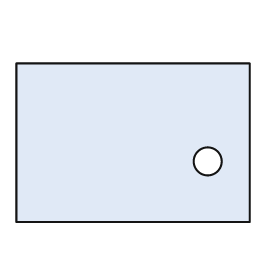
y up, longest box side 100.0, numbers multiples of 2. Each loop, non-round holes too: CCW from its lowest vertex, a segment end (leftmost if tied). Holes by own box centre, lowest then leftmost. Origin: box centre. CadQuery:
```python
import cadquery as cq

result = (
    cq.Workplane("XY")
    .moveTo(-50.0, -34.0)
    .lineTo(50.0, -34.0)
    .lineTo(50.0, 34.0)
    .lineTo(-50.0, 34.0)
    .close()
    .moveTo(32.0, -8.0)
    .circle(6.0)
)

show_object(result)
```